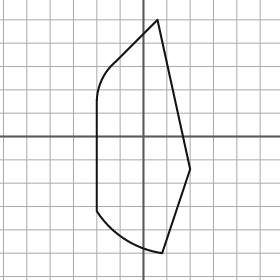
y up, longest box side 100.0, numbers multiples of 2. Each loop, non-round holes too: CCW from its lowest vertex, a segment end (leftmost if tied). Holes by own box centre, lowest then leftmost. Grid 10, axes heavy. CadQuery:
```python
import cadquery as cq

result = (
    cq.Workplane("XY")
    .moveTo(8.0, -50.0)
    .lineTo(20.0, -14.0)
    .lineTo(6.0, 50.0)
    .lineTo(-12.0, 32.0)
    .threePointArc((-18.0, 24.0), (-20.0, 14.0))
    .lineTo(-20.0, -32.0)
    .threePointArc((-8.0, -44.0), (8.0, -50.0))
    .close()
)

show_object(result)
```